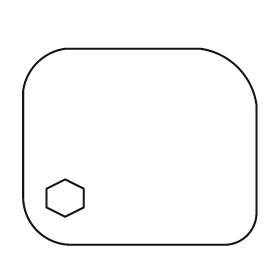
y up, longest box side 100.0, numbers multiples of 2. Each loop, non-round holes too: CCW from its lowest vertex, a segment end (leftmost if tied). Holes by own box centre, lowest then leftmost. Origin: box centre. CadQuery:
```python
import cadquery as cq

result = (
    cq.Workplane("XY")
    .moveTo(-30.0, -42.0)
    .lineTo(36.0, -42.0)
    .threePointArc((46.0, -38.0), (50.0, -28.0))
    .lineTo(50.0, 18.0)
    .threePointArc((42.0, 34.0), (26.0, 42.0))
    .lineTo(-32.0, 42.0)
    .threePointArc((-44.0, 36.0), (-50.0, 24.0))
    .lineTo(-50.0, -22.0)
    .threePointArc((-44.0, -36.0), (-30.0, -42.0))
    .close()
    .moveTo(-32.0, -30.0)
    .lineTo(-24.0, -26.0)
    .lineTo(-24.0, -18.0)
    .lineTo(-32.0, -14.0)
    .lineTo(-40.0, -18.0)
    .lineTo(-40.0, -26.0)
    .close()
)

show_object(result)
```